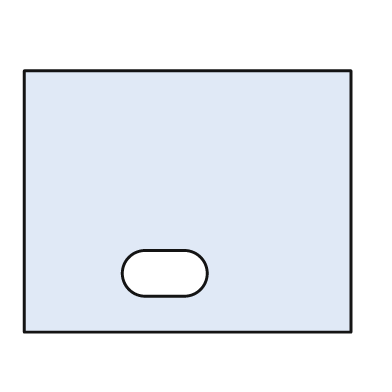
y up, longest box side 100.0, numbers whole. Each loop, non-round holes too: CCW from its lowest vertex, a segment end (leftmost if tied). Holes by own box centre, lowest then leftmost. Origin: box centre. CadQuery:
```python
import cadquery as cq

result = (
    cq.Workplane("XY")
    .moveTo(-50.0, -40.0)
    .lineTo(50.0, -40.0)
    .lineTo(50.0, 40.0)
    .lineTo(-50.0, 40.0)
    .close()
    .moveTo(-13.0, -29.0)
    .lineTo(-1.0, -29.0)
    .threePointArc((6.0, -22.0), (-1.0, -15.0))
    .lineTo(-13.0, -15.0)
    .threePointArc((-20.0, -22.0), (-13.0, -29.0))
    .close()
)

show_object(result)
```